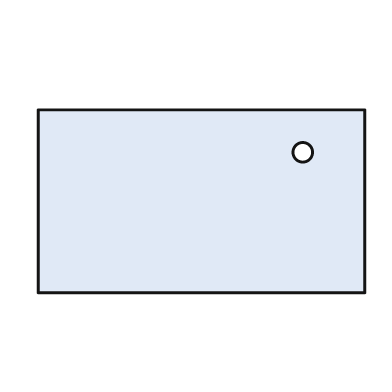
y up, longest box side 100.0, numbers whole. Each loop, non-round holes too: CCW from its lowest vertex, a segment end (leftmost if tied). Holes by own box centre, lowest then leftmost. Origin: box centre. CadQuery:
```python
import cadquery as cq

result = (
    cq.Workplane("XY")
    .moveTo(-50.0, -28.0)
    .lineTo(50.0, -28.0)
    .lineTo(50.0, 28.0)
    .lineTo(-50.0, 28.0)
    .close()
    .moveTo(31.0, 15.0)
    .circle(3.0)
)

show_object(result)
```